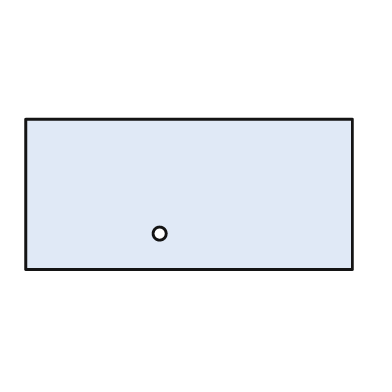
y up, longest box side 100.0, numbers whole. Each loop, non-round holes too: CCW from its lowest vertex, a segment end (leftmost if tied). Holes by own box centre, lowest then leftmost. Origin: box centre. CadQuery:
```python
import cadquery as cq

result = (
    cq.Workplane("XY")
    .moveTo(-50.0, -23.0)
    .lineTo(50.0, -23.0)
    .lineTo(50.0, 23.0)
    .lineTo(-50.0, 23.0)
    .close()
    .moveTo(-9.0, -12.0)
    .circle(2.0)
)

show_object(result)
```